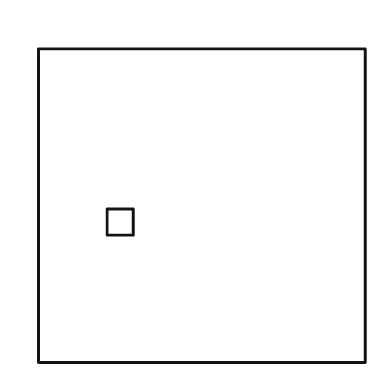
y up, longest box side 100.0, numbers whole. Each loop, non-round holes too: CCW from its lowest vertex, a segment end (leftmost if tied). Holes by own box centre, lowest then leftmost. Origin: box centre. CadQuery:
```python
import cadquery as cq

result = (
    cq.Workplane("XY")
    .moveTo(-50.0, -48.0)
    .lineTo(50.0, -48.0)
    .lineTo(50.0, 48.0)
    .lineTo(-50.0, 48.0)
    .close()
    .moveTo(-29.0, -9.0)
    .lineTo(-21.0, -9.0)
    .lineTo(-21.0, -1.0)
    .lineTo(-29.0, -1.0)
    .close()
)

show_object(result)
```